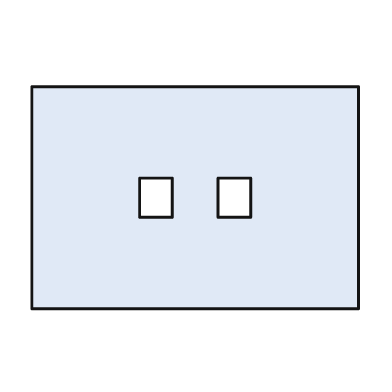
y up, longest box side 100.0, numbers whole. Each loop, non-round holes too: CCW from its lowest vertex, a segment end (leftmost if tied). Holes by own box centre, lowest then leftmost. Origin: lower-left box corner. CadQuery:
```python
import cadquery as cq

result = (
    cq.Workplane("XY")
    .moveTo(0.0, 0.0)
    .lineTo(100.0, 0.0)
    .lineTo(100.0, 68.0)
    .lineTo(0.0, 68.0)
    .close()
    .moveTo(33.0, 28.0)
    .lineTo(43.0, 28.0)
    .lineTo(43.0, 40.0)
    .lineTo(33.0, 40.0)
    .close()
    .moveTo(57.0, 28.0)
    .lineTo(67.0, 28.0)
    .lineTo(67.0, 40.0)
    .lineTo(57.0, 40.0)
    .close()
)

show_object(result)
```